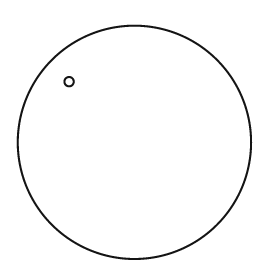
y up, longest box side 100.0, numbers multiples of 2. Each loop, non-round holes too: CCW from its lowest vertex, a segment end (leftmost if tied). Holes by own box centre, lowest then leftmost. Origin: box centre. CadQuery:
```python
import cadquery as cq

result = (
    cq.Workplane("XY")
    .moveTo(0.0, 0.0)
    .circle(50.0)
    .moveTo(-28.0, 26.0)
    .circle(2.0)
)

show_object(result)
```